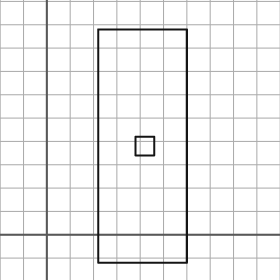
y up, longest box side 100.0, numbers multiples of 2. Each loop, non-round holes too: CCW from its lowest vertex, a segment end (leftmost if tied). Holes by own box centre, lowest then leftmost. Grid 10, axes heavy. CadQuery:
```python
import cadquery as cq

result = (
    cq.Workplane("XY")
    .moveTo(22.0, -12.0)
    .lineTo(60.0, -12.0)
    .lineTo(60.0, 88.0)
    .lineTo(22.0, 88.0)
    .close()
    .moveTo(38.0, 34.0)
    .lineTo(46.0, 34.0)
    .lineTo(46.0, 42.0)
    .lineTo(38.0, 42.0)
    .close()
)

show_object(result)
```